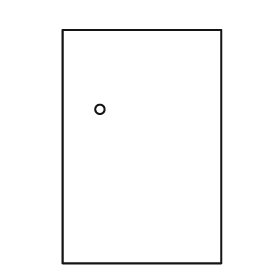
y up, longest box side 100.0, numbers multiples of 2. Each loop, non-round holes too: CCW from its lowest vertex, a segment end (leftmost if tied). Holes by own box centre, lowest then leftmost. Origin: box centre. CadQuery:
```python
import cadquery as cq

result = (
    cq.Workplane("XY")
    .moveTo(-34.0, -50.0)
    .lineTo(34.0, -50.0)
    .lineTo(34.0, 50.0)
    .lineTo(-34.0, 50.0)
    .close()
    .moveTo(-18.0, 16.0)
    .circle(2.0)
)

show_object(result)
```